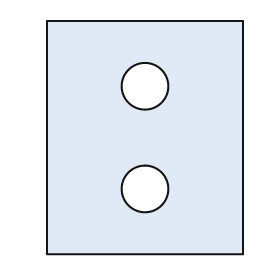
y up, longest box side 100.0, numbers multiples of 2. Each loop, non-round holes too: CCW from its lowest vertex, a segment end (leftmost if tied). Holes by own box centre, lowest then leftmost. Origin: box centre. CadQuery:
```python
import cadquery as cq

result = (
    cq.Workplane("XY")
    .moveTo(-42.0, -50.0)
    .lineTo(42.0, -50.0)
    .lineTo(42.0, 50.0)
    .lineTo(-42.0, 50.0)
    .close()
    .moveTo(0.0, -22.0)
    .circle(10.0)
    .moveTo(0.0, 22.0)
    .circle(10.0)
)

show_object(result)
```